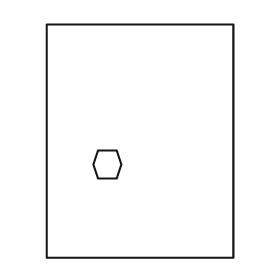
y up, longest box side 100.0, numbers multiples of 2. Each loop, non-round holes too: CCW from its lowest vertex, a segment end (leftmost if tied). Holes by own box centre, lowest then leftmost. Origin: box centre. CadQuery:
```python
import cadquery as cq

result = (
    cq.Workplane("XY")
    .moveTo(-40.0, -50.0)
    .lineTo(40.0, -50.0)
    .lineTo(40.0, 50.0)
    .lineTo(-40.0, 50.0)
    .close()
    .moveTo(-18.0, -16.0)
    .lineTo(-10.0, -16.0)
    .lineTo(-8.0, -10.0)
    .lineTo(-10.0, -4.0)
    .lineTo(-18.0, -4.0)
    .lineTo(-20.0, -10.0)
    .close()
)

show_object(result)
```